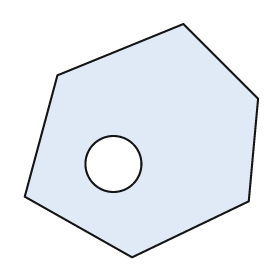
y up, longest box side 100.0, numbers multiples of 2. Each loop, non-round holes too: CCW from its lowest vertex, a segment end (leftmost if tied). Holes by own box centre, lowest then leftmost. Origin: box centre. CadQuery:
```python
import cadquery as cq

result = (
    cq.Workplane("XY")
    .moveTo(-4.0, -50.0)
    .lineTo(46.0, -26.0)
    .lineTo(50.0, 18.0)
    .lineTo(18.0, 50.0)
    .lineTo(-36.0, 28.0)
    .lineTo(-50.0, -24.0)
    .close()
    .moveTo(-12.0, -10.0)
    .circle(12.0)
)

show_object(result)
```